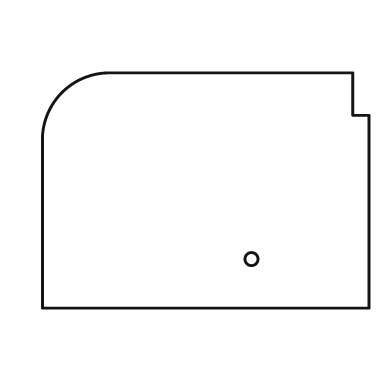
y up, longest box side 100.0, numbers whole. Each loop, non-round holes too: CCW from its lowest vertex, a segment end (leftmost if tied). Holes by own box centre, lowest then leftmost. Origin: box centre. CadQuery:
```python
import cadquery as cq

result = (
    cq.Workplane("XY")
    .moveTo(-50.0, -36.0)
    .lineTo(50.0, -36.0)
    .lineTo(50.0, 23.0)
    .lineTo(45.0, 23.0)
    .lineTo(45.0, 36.0)
    .lineTo(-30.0, 36.0)
    .threePointArc((-44.0, 30.0), (-50.0, 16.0))
    .close()
    .moveTo(14.0, -21.0)
    .circle(2.0)
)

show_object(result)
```